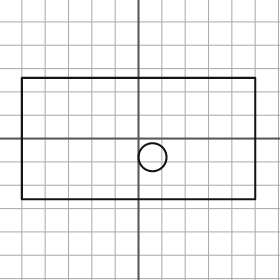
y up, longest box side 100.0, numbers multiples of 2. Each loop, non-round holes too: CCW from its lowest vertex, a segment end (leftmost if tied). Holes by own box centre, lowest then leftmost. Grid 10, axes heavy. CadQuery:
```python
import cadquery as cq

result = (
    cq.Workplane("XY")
    .moveTo(-50.0, -26.0)
    .lineTo(50.0, -26.0)
    .lineTo(50.0, 26.0)
    .lineTo(-50.0, 26.0)
    .close()
    .moveTo(6.0, -8.0)
    .circle(6.0)
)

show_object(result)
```